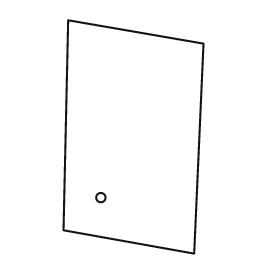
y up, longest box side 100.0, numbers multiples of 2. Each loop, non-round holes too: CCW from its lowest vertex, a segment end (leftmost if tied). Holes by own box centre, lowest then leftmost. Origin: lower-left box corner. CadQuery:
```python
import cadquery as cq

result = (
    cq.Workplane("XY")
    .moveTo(56.0, 0.0)
    .lineTo(60.0, 90.0)
    .lineTo(2.0, 100.0)
    .lineTo(0.0, 10.0)
    .close()
    .moveTo(16.0, 24.0)
    .circle(2.0)
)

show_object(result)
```